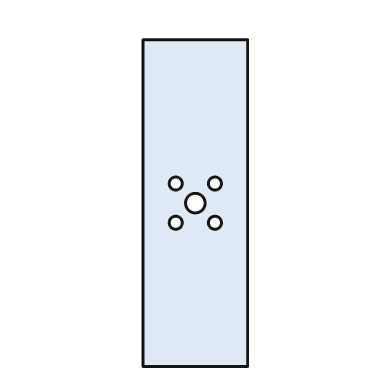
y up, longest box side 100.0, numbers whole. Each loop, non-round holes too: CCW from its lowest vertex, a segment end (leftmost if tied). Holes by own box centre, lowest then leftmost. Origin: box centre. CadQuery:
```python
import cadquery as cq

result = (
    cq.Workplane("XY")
    .moveTo(-16.0, -50.0)
    .lineTo(16.0, -50.0)
    .lineTo(16.0, 50.0)
    .lineTo(-16.0, 50.0)
    .close()
    .moveTo(-6.0, -6.0)
    .circle(2.0)
    .moveTo(6.0, -6.0)
    .circle(2.0)
    .moveTo(0.0, 0.0)
    .circle(3.0)
    .moveTo(-6.0, 6.0)
    .circle(2.0)
    .moveTo(6.0, 6.0)
    .circle(2.0)
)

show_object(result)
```